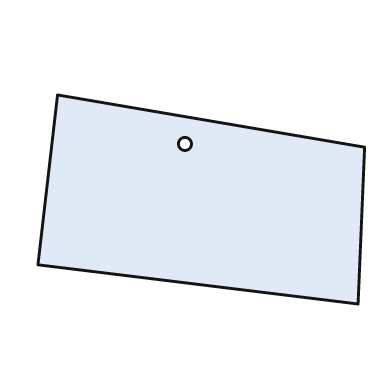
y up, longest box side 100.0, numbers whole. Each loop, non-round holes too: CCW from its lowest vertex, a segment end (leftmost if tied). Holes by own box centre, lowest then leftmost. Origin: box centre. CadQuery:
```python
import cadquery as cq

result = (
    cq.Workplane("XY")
    .moveTo(48.0, -32.0)
    .lineTo(50.0, 16.0)
    .lineTo(-44.0, 32.0)
    .lineTo(-50.0, -20.0)
    .close()
    .moveTo(-5.0, 17.0)
    .circle(2.0)
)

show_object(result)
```